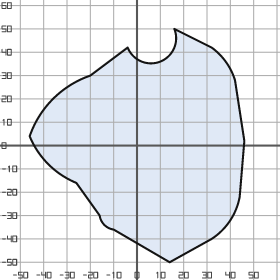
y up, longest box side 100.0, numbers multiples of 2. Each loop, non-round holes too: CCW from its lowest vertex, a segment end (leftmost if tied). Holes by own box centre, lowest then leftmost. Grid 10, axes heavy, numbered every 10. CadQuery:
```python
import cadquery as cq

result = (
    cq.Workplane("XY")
    .moveTo(14.0, -50.0)
    .lineTo(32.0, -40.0)
    .threePointArc((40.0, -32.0), (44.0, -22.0))
    .lineTo(46.0, 2.0)
    .lineTo(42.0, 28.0)
    .threePointArc((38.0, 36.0), (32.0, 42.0))
    .lineTo(16.0, 50.0)
    .threePointArc((10.0, 36.0), (-4.0, 42.0))
    .lineTo(-20.0, 30.0)
    .threePointArc((-36.0, 20.0), (-46.0, 4.0))
    .threePointArc((-38.0, -8.0), (-26.0, -16.0))
    .lineTo(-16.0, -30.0)
    .threePointArc((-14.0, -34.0), (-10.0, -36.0))
    .close()
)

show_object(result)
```